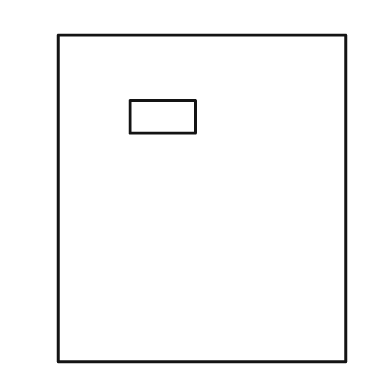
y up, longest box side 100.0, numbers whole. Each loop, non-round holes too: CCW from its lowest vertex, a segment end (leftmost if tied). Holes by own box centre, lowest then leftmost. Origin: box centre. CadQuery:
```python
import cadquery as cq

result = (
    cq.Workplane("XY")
    .moveTo(-44.0, -50.0)
    .lineTo(44.0, -50.0)
    .lineTo(44.0, 50.0)
    .lineTo(-44.0, 50.0)
    .close()
    .moveTo(-22.0, 20.0)
    .lineTo(-2.0, 20.0)
    .lineTo(-2.0, 30.0)
    .lineTo(-22.0, 30.0)
    .close()
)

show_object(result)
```